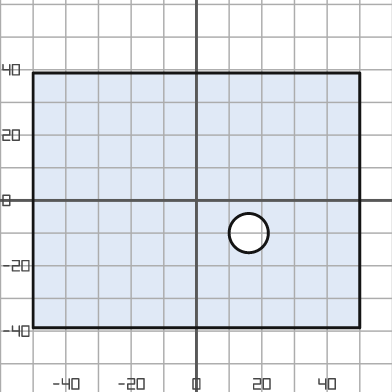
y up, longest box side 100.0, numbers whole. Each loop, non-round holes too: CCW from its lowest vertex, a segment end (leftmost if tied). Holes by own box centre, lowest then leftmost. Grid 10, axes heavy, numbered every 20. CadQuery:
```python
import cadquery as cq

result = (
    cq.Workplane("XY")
    .moveTo(-50.0, -39.0)
    .lineTo(50.0, -39.0)
    .lineTo(50.0, 39.0)
    .lineTo(-50.0, 39.0)
    .close()
    .moveTo(16.0, -10.0)
    .circle(6.0)
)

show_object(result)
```